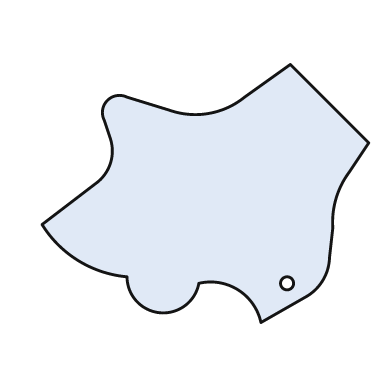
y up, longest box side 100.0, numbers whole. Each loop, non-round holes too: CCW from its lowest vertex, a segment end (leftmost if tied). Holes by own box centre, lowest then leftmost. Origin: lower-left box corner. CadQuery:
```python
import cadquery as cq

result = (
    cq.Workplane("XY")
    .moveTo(67.0, 0.0)
    .lineTo(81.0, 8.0)
    .threePointArc((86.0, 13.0), (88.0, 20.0))
    .lineTo(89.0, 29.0)
    .threePointArc((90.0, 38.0), (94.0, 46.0))
    .lineTo(100.0, 55.0)
    .lineTo(76.0, 79.0)
    .lineTo(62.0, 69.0)
    .threePointArc((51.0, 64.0), (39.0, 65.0))
    .lineTo(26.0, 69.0)
    .threePointArc((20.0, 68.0), (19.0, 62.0))
    .lineTo(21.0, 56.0)
    .threePointArc((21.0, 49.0), (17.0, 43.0))
    .lineTo(0.0, 30.0)
    .threePointArc((11.0, 19.0), (26.0, 14.0))
    .threePointArc((36.0, 3.0), (48.0, 12.0))
    .threePointArc((60.0, 10.0), (67.0, 0.0))
    .close()
    .moveTo(75.0, 12.0)
    .circle(2.0)
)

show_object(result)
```